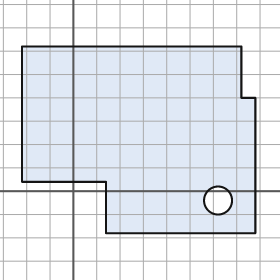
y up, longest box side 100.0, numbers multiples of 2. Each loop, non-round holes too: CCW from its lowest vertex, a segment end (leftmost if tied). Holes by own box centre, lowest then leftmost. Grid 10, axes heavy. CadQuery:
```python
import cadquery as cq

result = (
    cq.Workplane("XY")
    .moveTo(14.0, -18.0)
    .lineTo(78.0, -18.0)
    .lineTo(78.0, 40.0)
    .lineTo(72.0, 40.0)
    .lineTo(72.0, 62.0)
    .lineTo(-22.0, 62.0)
    .lineTo(-22.0, 4.0)
    .lineTo(14.0, 4.0)
    .close()
    .moveTo(62.0, -4.0)
    .circle(6.0)
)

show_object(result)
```